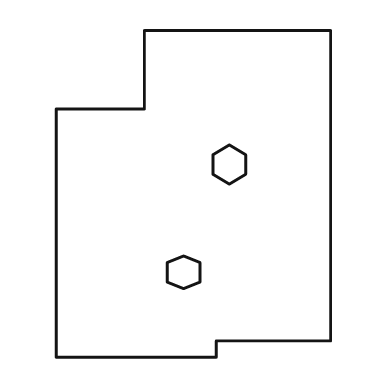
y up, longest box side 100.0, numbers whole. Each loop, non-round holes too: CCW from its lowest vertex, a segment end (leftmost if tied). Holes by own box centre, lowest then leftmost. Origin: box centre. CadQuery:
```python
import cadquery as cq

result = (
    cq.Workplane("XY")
    .moveTo(-42.0, -50.0)
    .lineTo(7.0, -50.0)
    .lineTo(7.0, -45.0)
    .lineTo(42.0, -45.0)
    .lineTo(42.0, 50.0)
    .lineTo(-15.0, 50.0)
    .lineTo(-15.0, 26.0)
    .lineTo(-42.0, 26.0)
    .close()
    .moveTo(-3.0, -29.0)
    .lineTo(2.0, -27.0)
    .lineTo(2.0, -21.0)
    .lineTo(-3.0, -19.0)
    .lineTo(-8.0, -21.0)
    .lineTo(-8.0, -27.0)
    .close()
    .moveTo(11.0, 3.0)
    .lineTo(16.0, 6.0)
    .lineTo(16.0, 12.0)
    .lineTo(11.0, 15.0)
    .lineTo(6.0, 12.0)
    .lineTo(6.0, 6.0)
    .close()
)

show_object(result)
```